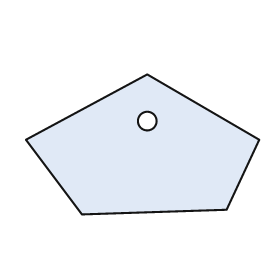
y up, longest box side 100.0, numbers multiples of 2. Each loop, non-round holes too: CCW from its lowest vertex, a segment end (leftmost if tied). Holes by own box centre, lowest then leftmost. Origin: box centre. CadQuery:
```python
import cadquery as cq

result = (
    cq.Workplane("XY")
    .moveTo(-26.0, -30.0)
    .lineTo(36.0, -28.0)
    .lineTo(50.0, 2.0)
    .lineTo(2.0, 30.0)
    .lineTo(-50.0, 2.0)
    .close()
    .moveTo(2.0, 10.0)
    .circle(4.0)
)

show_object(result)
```